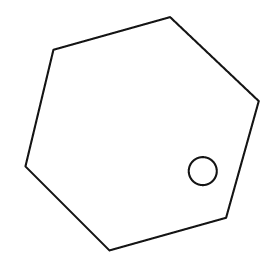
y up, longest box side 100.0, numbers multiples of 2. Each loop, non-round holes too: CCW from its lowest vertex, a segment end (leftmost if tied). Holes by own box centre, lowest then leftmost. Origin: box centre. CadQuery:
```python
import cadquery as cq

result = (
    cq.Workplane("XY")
    .moveTo(-14.0, -50.0)
    .lineTo(36.0, -36.0)
    .lineTo(50.0, 14.0)
    .lineTo(12.0, 50.0)
    .lineTo(-38.0, 36.0)
    .lineTo(-50.0, -14.0)
    .close()
    .moveTo(26.0, -16.0)
    .circle(6.0)
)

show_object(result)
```